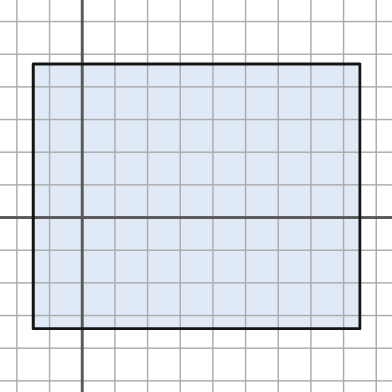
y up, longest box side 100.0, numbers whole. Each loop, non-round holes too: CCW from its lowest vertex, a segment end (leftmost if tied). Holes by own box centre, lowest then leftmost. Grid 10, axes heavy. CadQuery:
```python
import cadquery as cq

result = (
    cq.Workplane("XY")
    .moveTo(-15.0, -34.0)
    .lineTo(85.0, -34.0)
    .lineTo(85.0, 47.0)
    .lineTo(-15.0, 47.0)
    .close()
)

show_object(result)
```